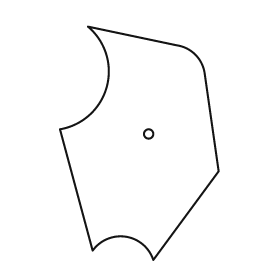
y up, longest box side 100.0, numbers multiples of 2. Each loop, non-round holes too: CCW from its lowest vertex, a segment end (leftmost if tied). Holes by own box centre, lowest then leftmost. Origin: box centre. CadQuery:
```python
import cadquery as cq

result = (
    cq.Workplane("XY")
    .moveTo(6.0, -50.0)
    .lineTo(34.0, -12.0)
    .lineTo(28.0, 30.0)
    .threePointArc((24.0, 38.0), (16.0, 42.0))
    .lineTo(-22.0, 50.0)
    .threePointArc((-14.0, 24.0), (-34.0, 6.0))
    .lineTo(-20.0, -46.0)
    .threePointArc((-6.0, -40.0), (6.0, -50.0))
    .close()
    .moveTo(4.0, 4.0)
    .circle(2.0)
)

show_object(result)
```